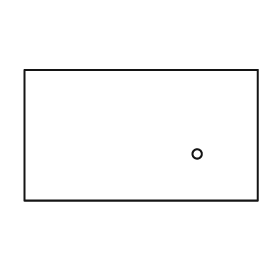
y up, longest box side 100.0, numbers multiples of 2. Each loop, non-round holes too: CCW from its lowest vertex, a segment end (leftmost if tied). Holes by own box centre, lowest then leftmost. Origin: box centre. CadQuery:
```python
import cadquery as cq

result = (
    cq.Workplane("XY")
    .moveTo(-50.0, -28.0)
    .lineTo(50.0, -28.0)
    .lineTo(50.0, 28.0)
    .lineTo(-50.0, 28.0)
    .close()
    .moveTo(24.0, -8.0)
    .circle(2.0)
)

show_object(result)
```